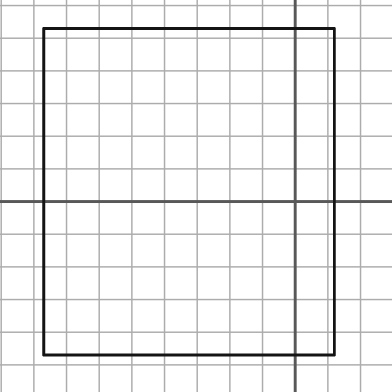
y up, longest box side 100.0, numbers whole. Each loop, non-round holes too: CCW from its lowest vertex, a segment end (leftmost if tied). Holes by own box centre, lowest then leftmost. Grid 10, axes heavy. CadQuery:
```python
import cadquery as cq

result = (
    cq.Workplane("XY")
    .moveTo(-77.0, -47.0)
    .lineTo(12.0, -47.0)
    .lineTo(12.0, 53.0)
    .lineTo(-77.0, 53.0)
    .close()
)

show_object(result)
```